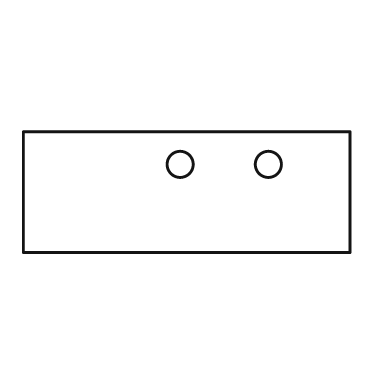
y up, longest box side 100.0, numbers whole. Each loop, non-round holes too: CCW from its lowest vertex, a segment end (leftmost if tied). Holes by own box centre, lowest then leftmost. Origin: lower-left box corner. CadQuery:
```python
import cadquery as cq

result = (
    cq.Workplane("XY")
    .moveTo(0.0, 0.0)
    .lineTo(100.0, 0.0)
    .lineTo(100.0, 37.0)
    .lineTo(0.0, 37.0)
    .close()
    .moveTo(48.0, 27.0)
    .circle(4.0)
    .moveTo(75.0, 27.0)
    .circle(4.0)
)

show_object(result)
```